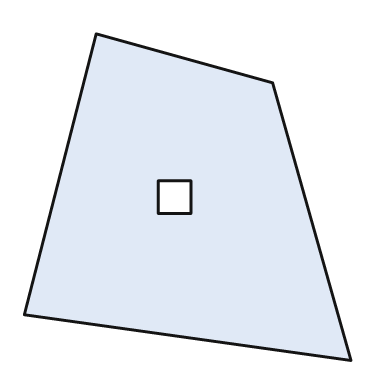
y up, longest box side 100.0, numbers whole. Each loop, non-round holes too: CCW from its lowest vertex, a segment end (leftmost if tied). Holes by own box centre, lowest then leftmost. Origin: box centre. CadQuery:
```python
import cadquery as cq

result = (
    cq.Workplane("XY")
    .moveTo(50.0, -50.0)
    .lineTo(26.0, 35.0)
    .lineTo(-28.0, 50.0)
    .lineTo(-50.0, -36.0)
    .close()
    .moveTo(-9.0, -5.0)
    .lineTo(1.0, -5.0)
    .lineTo(1.0, 5.0)
    .lineTo(-9.0, 5.0)
    .close()
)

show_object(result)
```